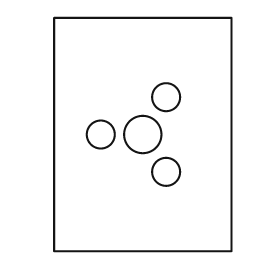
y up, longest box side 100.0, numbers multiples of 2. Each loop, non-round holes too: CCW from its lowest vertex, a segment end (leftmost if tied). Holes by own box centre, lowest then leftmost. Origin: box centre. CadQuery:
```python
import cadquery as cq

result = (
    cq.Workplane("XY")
    .moveTo(-38.0, -50.0)
    .lineTo(38.0, -50.0)
    .lineTo(38.0, 50.0)
    .lineTo(-38.0, 50.0)
    .close()
    .moveTo(10.0, -16.0)
    .circle(6.0)
    .moveTo(-18.0, 0.0)
    .circle(6.0)
    .moveTo(0.0, 0.0)
    .circle(8.0)
    .moveTo(10.0, 16.0)
    .circle(6.0)
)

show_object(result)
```